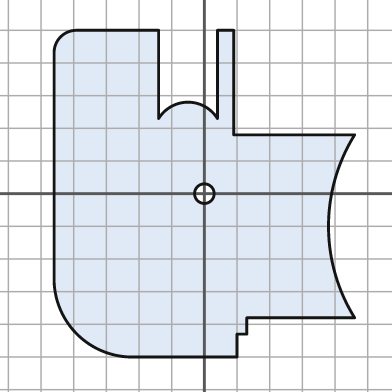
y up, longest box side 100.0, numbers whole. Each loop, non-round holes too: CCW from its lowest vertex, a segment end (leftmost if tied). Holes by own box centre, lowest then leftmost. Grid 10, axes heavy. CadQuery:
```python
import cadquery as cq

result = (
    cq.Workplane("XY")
    .moveTo(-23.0, -50.0)
    .lineTo(10.0, -50.0)
    .lineTo(10.0, -43.0)
    .lineTo(13.0, -43.0)
    .lineTo(13.0, -38.0)
    .lineTo(46.0, -38.0)
    .threePointArc((38.0, -10.0), (46.0, 18.0))
    .lineTo(9.0, 18.0)
    .lineTo(9.0, 50.0)
    .lineTo(4.0, 50.0)
    .lineTo(4.0, 23.0)
    .threePointArc((-5.0, 28.0), (-14.0, 23.0))
    .lineTo(-14.0, 50.0)
    .lineTo(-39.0, 50.0)
    .threePointArc((-44.0, 48.0), (-46.0, 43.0))
    .lineTo(-46.0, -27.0)
    .threePointArc((-39.0, -43.0), (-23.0, -50.0))
    .close()
    .moveTo(0.0, 0.0)
    .circle(3.0)
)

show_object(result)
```